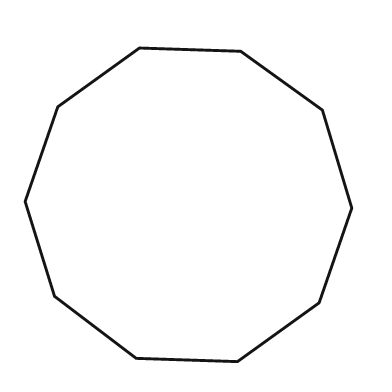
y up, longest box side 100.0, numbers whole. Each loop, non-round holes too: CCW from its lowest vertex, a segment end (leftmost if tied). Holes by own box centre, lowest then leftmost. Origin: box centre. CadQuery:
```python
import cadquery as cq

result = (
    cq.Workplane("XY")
    .moveTo(15.0, -48.0)
    .lineTo(40.0, -30.0)
    .lineTo(50.0, -1.0)
    .lineTo(41.0, 29.0)
    .lineTo(16.0, 47.0)
    .lineTo(-15.0, 48.0)
    .lineTo(-40.0, 30.0)
    .lineTo(-50.0, 1.0)
    .lineTo(-41.0, -28.0)
    .lineTo(-16.0, -47.0)
    .close()
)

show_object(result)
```